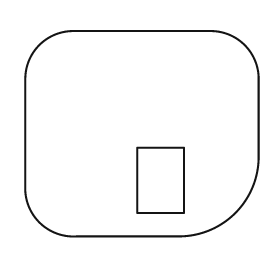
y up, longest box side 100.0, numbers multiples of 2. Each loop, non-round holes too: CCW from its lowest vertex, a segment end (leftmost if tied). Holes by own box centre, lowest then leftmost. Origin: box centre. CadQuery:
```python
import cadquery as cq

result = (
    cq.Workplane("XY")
    .moveTo(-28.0, -44.0)
    .lineTo(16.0, -44.0)
    .threePointArc((40.0, -34.0), (50.0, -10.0))
    .lineTo(50.0, 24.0)
    .threePointArc((44.0, 38.0), (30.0, 44.0))
    .lineTo(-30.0, 44.0)
    .threePointArc((-44.0, 38.0), (-50.0, 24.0))
    .lineTo(-50.0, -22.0)
    .threePointArc((-44.0, -38.0), (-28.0, -44.0))
    .close()
    .moveTo(-2.0, -34.0)
    .lineTo(18.0, -34.0)
    .lineTo(18.0, -6.0)
    .lineTo(-2.0, -6.0)
    .close()
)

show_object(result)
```